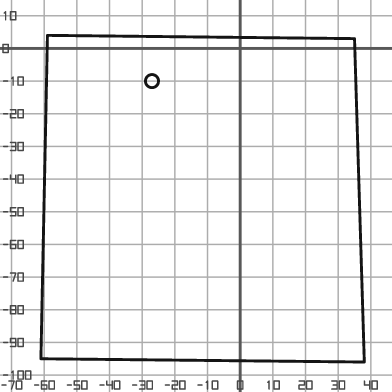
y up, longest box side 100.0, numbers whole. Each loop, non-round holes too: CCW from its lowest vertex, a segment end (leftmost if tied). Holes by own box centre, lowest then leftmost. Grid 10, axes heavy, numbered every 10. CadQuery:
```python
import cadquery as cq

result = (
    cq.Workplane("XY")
    .moveTo(38.0, -96.0)
    .lineTo(35.0, 3.0)
    .lineTo(-59.0, 4.0)
    .lineTo(-61.0, -95.0)
    .close()
    .moveTo(-27.0, -10.0)
    .circle(2.0)
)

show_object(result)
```